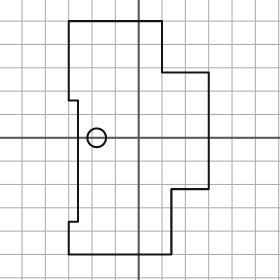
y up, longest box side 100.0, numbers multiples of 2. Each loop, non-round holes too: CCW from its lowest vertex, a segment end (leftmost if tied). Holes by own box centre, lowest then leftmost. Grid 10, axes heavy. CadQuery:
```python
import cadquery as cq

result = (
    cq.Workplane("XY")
    .moveTo(-30.0, -50.0)
    .lineTo(14.0, -50.0)
    .lineTo(14.0, -22.0)
    .lineTo(30.0, -22.0)
    .lineTo(30.0, 28.0)
    .lineTo(10.0, 28.0)
    .lineTo(10.0, 50.0)
    .lineTo(-30.0, 50.0)
    .lineTo(-30.0, 16.0)
    .lineTo(-26.0, 16.0)
    .lineTo(-26.0, -36.0)
    .lineTo(-30.0, -36.0)
    .close()
    .moveTo(-18.0, 0.0)
    .circle(4.0)
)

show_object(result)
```